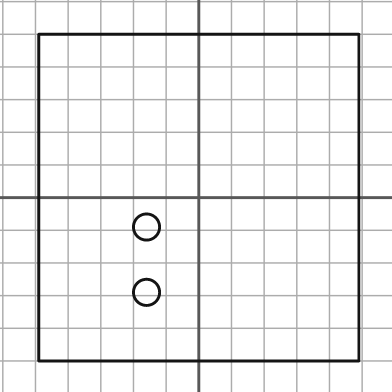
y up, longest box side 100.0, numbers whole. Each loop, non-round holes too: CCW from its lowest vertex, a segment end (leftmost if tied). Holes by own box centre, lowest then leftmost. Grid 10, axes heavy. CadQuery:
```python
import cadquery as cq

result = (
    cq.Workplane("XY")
    .moveTo(-49.0, -50.0)
    .lineTo(49.0, -50.0)
    .lineTo(49.0, 50.0)
    .lineTo(-49.0, 50.0)
    .close()
    .moveTo(-16.0, -29.0)
    .circle(4.0)
    .moveTo(-16.0, -9.0)
    .circle(4.0)
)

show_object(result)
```